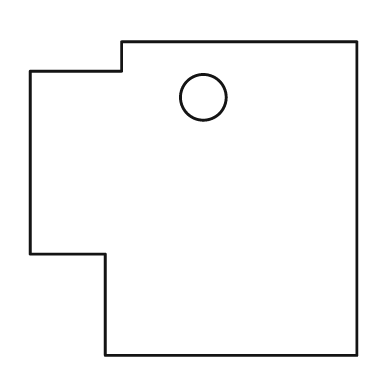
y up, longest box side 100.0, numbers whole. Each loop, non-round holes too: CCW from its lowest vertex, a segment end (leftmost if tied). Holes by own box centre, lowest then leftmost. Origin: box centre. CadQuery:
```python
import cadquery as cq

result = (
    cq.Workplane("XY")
    .moveTo(-27.0, -48.0)
    .lineTo(50.0, -48.0)
    .lineTo(50.0, 48.0)
    .lineTo(-22.0, 48.0)
    .lineTo(-22.0, 39.0)
    .lineTo(-50.0, 39.0)
    .lineTo(-50.0, -17.0)
    .lineTo(-27.0, -17.0)
    .close()
    .moveTo(3.0, 31.0)
    .circle(7.0)
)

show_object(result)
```